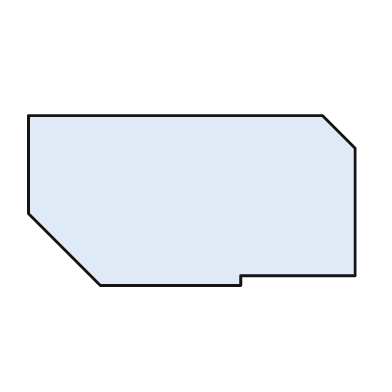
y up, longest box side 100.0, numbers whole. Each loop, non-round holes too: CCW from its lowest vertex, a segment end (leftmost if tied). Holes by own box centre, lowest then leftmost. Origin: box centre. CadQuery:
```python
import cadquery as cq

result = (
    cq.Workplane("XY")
    .moveTo(-28.0, -26.0)
    .lineTo(15.0, -26.0)
    .lineTo(15.0, -23.0)
    .lineTo(50.0, -23.0)
    .lineTo(50.0, 16.0)
    .lineTo(40.0, 26.0)
    .lineTo(-50.0, 26.0)
    .lineTo(-50.0, -4.0)
    .close()
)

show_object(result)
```